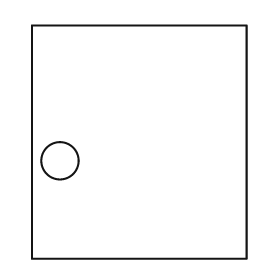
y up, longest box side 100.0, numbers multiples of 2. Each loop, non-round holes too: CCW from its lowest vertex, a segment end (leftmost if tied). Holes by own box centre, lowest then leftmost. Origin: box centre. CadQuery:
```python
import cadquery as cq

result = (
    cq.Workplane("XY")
    .moveTo(-46.0, -50.0)
    .lineTo(46.0, -50.0)
    .lineTo(46.0, 50.0)
    .lineTo(-46.0, 50.0)
    .close()
    .moveTo(-34.0, -8.0)
    .circle(8.0)
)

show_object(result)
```